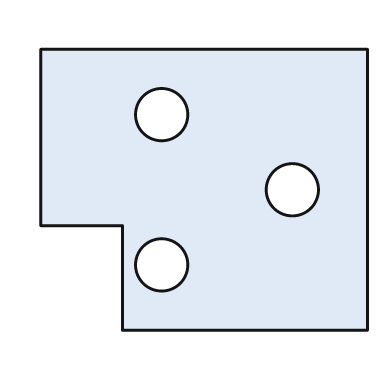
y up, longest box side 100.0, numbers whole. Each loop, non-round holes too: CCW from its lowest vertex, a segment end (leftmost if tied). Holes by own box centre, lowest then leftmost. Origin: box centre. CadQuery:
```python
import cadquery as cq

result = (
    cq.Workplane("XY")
    .moveTo(-25.0, -43.0)
    .lineTo(50.0, -43.0)
    .lineTo(50.0, 43.0)
    .lineTo(-50.0, 43.0)
    .lineTo(-50.0, -11.0)
    .lineTo(-25.0, -11.0)
    .close()
    .moveTo(-13.0, -23.0)
    .circle(8.0)
    .moveTo(27.0, 0.0)
    .circle(8.0)
    .moveTo(-13.0, 23.0)
    .circle(8.0)
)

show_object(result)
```